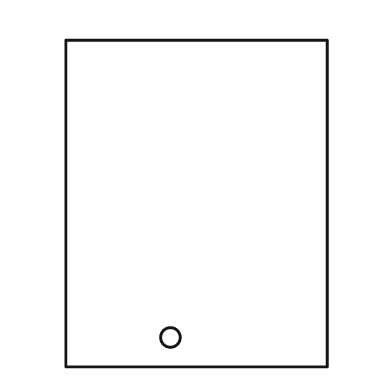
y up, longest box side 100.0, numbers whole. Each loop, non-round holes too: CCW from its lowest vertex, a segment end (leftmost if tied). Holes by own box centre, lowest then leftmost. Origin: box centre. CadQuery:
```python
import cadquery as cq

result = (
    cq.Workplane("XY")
    .moveTo(-40.0, -50.0)
    .lineTo(40.0, -50.0)
    .lineTo(40.0, 50.0)
    .lineTo(-40.0, 50.0)
    .close()
    .moveTo(-8.0, -41.0)
    .circle(3.0)
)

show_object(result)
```